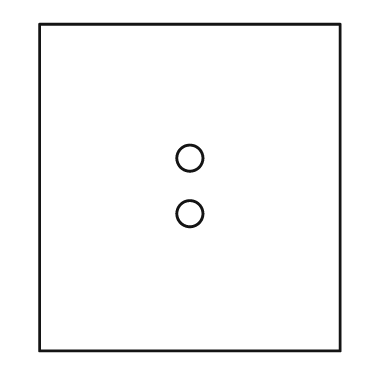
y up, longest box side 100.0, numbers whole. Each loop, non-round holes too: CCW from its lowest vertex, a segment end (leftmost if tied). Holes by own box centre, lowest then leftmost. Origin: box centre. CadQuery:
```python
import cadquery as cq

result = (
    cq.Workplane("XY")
    .moveTo(-46.0, -50.0)
    .lineTo(46.0, -50.0)
    .lineTo(46.0, 50.0)
    .lineTo(-46.0, 50.0)
    .close()
    .moveTo(0.0, -8.0)
    .circle(4.0)
    .moveTo(0.0, 9.0)
    .circle(4.0)
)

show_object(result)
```